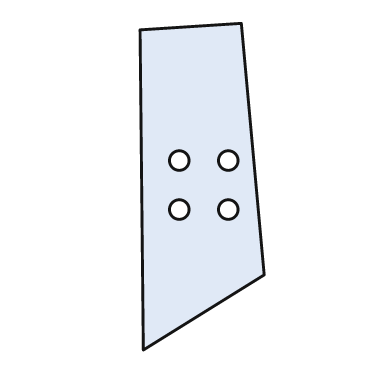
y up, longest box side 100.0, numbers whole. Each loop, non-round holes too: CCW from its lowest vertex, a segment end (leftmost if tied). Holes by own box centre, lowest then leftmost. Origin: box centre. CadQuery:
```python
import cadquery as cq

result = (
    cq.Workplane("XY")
    .moveTo(-18.0, -50.0)
    .lineTo(19.0, -27.0)
    .lineTo(12.0, 50.0)
    .lineTo(-19.0, 48.0)
    .close()
    .moveTo(-7.0, -7.0)
    .circle(3.0)
    .moveTo(8.0, -7.0)
    .circle(3.0)
    .moveTo(-7.0, 8.0)
    .circle(3.0)
    .moveTo(8.0, 8.0)
    .circle(3.0)
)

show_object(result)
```